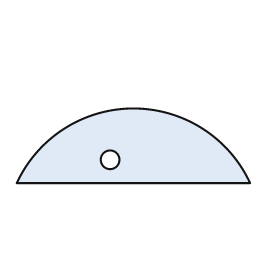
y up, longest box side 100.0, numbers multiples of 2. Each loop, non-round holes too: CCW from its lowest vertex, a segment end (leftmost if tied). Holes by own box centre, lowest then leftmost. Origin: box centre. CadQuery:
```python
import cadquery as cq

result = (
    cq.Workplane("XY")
    .moveTo(-50.0, -16.0)
    .lineTo(50.0, -16.0)
    .threePointArc((0.0, 16.0), (-50.0, -16.0))
    .close()
    .moveTo(-10.0, -6.0)
    .circle(4.0)
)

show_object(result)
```